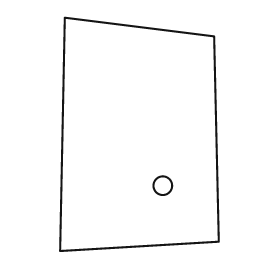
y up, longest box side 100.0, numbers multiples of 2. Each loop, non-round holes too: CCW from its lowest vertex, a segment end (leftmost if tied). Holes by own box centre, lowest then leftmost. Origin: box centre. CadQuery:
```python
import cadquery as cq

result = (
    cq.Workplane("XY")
    .moveTo(-34.0, -50.0)
    .lineTo(34.0, -46.0)
    .lineTo(32.0, 42.0)
    .lineTo(-32.0, 50.0)
    .close()
    .moveTo(10.0, -22.0)
    .circle(4.0)
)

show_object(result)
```